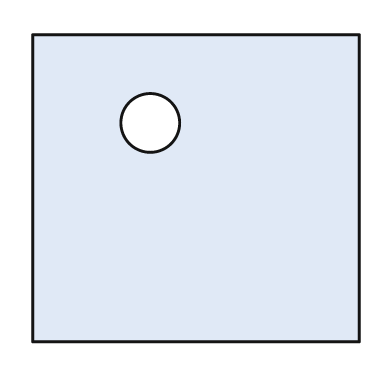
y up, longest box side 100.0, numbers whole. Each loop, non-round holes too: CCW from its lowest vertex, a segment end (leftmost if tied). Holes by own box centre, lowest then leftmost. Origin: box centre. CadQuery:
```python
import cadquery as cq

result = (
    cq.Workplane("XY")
    .moveTo(-50.0, -47.0)
    .lineTo(50.0, -47.0)
    .lineTo(50.0, 47.0)
    .lineTo(-50.0, 47.0)
    .close()
    .moveTo(-14.0, 20.0)
    .circle(9.0)
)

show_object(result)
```